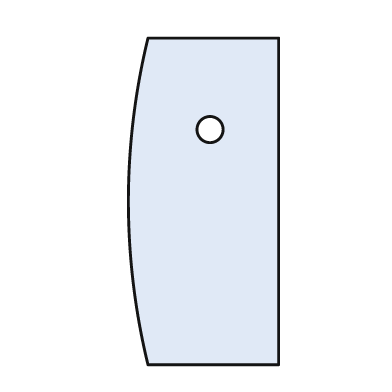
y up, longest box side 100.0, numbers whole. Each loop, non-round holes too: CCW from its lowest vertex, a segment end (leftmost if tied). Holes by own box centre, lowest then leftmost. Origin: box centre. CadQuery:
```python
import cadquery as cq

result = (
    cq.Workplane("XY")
    .moveTo(-17.0, -50.0)
    .lineTo(23.0, -50.0)
    .lineTo(23.0, 50.0)
    .lineTo(-17.0, 50.0)
    .threePointArc((-23.0, 0.0), (-17.0, -50.0))
    .close()
    .moveTo(2.0, 22.0)
    .circle(4.0)
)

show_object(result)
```